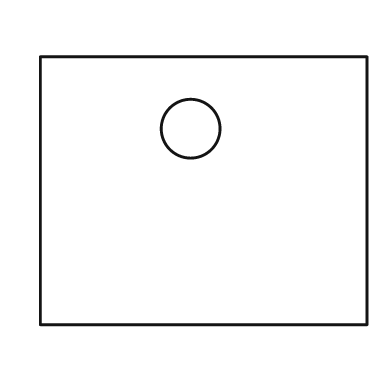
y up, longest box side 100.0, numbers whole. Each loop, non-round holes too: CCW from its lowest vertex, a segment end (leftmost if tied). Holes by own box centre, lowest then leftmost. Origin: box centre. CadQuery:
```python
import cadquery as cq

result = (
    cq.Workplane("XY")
    .moveTo(-50.0, -41.0)
    .lineTo(50.0, -41.0)
    .lineTo(50.0, 41.0)
    .lineTo(-50.0, 41.0)
    .close()
    .moveTo(-4.0, 19.0)
    .circle(9.0)
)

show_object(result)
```